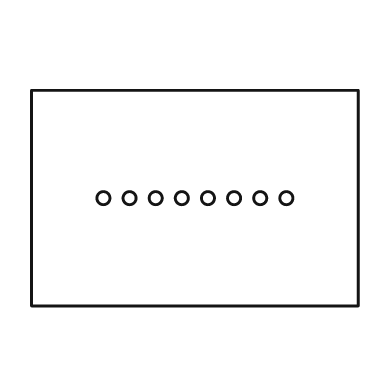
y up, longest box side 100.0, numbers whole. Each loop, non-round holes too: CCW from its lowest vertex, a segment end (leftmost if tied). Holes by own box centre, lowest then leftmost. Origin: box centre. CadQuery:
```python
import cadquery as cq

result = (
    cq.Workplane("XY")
    .moveTo(-50.0, -33.0)
    .lineTo(50.0, -33.0)
    .lineTo(50.0, 33.0)
    .lineTo(-50.0, 33.0)
    .close()
    .moveTo(-28.0, 0.0)
    .circle(2.0)
    .moveTo(-20.0, 0.0)
    .circle(2.0)
    .moveTo(-12.0, 0.0)
    .circle(2.0)
    .moveTo(-4.0, 0.0)
    .circle(2.0)
    .moveTo(4.0, 0.0)
    .circle(2.0)
    .moveTo(12.0, 0.0)
    .circle(2.0)
    .moveTo(20.0, 0.0)
    .circle(2.0)
    .moveTo(28.0, 0.0)
    .circle(2.0)
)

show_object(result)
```